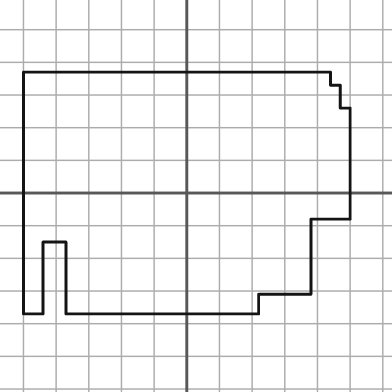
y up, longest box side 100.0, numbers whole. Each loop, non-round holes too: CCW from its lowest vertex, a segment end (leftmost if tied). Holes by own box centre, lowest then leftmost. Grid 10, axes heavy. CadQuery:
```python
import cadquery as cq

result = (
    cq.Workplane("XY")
    .moveTo(-50.0, -37.0)
    .lineTo(-44.0, -37.0)
    .lineTo(-44.0, -15.0)
    .lineTo(-37.0, -15.0)
    .lineTo(-37.0, -37.0)
    .lineTo(22.0, -37.0)
    .lineTo(22.0, -31.0)
    .lineTo(38.0, -31.0)
    .lineTo(38.0, -8.0)
    .lineTo(50.0, -8.0)
    .lineTo(50.0, 26.0)
    .lineTo(47.0, 26.0)
    .lineTo(47.0, 33.0)
    .lineTo(44.0, 33.0)
    .lineTo(44.0, 37.0)
    .lineTo(-50.0, 37.0)
    .close()
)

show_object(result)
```